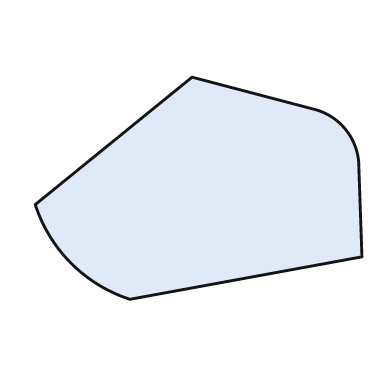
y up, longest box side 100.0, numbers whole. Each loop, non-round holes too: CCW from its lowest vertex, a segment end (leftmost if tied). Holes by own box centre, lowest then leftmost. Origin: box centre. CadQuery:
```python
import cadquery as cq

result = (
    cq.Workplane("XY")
    .moveTo(-21.0, -34.0)
    .lineTo(50.0, -21.0)
    .lineTo(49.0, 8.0)
    .threePointArc((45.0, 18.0), (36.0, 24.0))
    .lineTo(-2.0, 34.0)
    .lineTo(-50.0, -5.0)
    .threePointArc((-39.0, -23.0), (-21.0, -34.0))
    .close()
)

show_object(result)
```